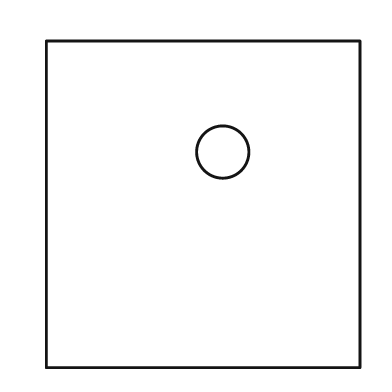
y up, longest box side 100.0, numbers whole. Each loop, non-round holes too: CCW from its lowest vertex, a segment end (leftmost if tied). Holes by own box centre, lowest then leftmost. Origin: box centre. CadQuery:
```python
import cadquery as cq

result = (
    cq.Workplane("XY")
    .moveTo(-48.0, -50.0)
    .lineTo(48.0, -50.0)
    .lineTo(48.0, 50.0)
    .lineTo(-48.0, 50.0)
    .close()
    .moveTo(6.0, 16.0)
    .circle(8.0)
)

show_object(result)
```